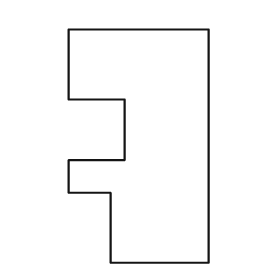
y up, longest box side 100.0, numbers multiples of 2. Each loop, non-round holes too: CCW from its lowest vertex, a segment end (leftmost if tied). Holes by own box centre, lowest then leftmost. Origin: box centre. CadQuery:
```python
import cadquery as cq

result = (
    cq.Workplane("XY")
    .moveTo(-12.0, -50.0)
    .lineTo(30.0, -50.0)
    .lineTo(30.0, 50.0)
    .lineTo(-30.0, 50.0)
    .lineTo(-30.0, 20.0)
    .lineTo(-6.0, 20.0)
    .lineTo(-6.0, -6.0)
    .lineTo(-30.0, -6.0)
    .lineTo(-30.0, -20.0)
    .lineTo(-12.0, -20.0)
    .close()
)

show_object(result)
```